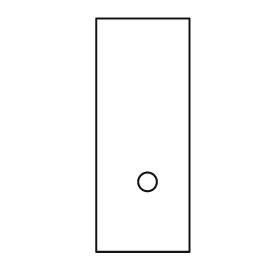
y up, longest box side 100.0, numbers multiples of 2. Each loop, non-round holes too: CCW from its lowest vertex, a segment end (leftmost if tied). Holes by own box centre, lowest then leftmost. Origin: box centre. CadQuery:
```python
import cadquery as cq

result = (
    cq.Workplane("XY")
    .moveTo(-20.0, -50.0)
    .lineTo(20.0, -50.0)
    .lineTo(20.0, 50.0)
    .lineTo(-20.0, 50.0)
    .close()
    .moveTo(2.0, -20.0)
    .circle(4.0)
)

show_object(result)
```